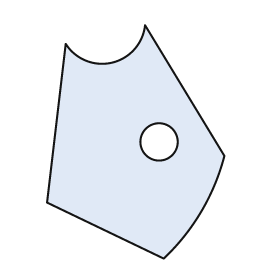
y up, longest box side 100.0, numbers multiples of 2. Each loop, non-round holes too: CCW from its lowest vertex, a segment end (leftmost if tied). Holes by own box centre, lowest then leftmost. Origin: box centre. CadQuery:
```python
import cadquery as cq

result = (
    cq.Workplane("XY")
    .moveTo(12.0, -50.0)
    .threePointArc((28.0, -30.0), (38.0, -6.0))
    .lineTo(4.0, 50.0)
    .threePointArc((-10.0, 34.0), (-30.0, 42.0))
    .lineTo(-38.0, -26.0)
    .close()
    .moveTo(10.0, 0.0)
    .circle(8.0)
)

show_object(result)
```